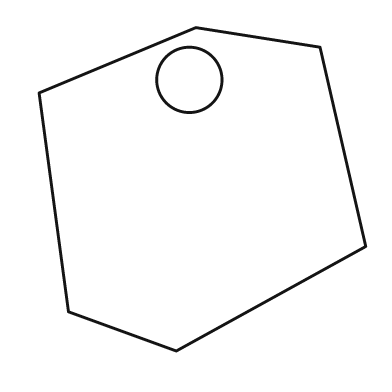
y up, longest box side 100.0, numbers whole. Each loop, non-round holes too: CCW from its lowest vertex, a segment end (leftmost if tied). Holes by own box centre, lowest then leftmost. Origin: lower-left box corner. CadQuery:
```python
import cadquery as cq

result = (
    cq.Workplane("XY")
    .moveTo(42.0, 0.0)
    .lineTo(100.0, 32.0)
    .lineTo(86.0, 93.0)
    .lineTo(48.0, 99.0)
    .lineTo(0.0, 79.0)
    .lineTo(9.0, 12.0)
    .close()
    .moveTo(46.0, 83.0)
    .circle(10.0)
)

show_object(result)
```